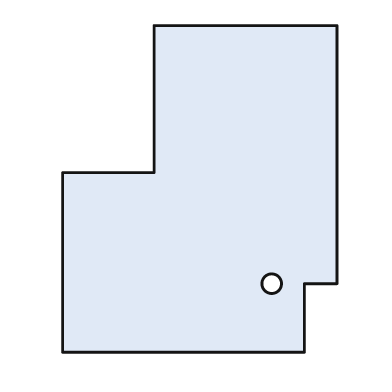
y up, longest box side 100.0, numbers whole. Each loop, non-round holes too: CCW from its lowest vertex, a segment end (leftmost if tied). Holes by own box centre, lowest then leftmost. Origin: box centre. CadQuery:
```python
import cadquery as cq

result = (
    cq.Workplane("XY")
    .moveTo(-42.0, -50.0)
    .lineTo(32.0, -50.0)
    .lineTo(32.0, -29.0)
    .lineTo(42.0, -29.0)
    .lineTo(42.0, 50.0)
    .lineTo(-14.0, 50.0)
    .lineTo(-14.0, 5.0)
    .lineTo(-42.0, 5.0)
    .close()
    .moveTo(22.0, -29.0)
    .circle(3.0)
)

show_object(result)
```